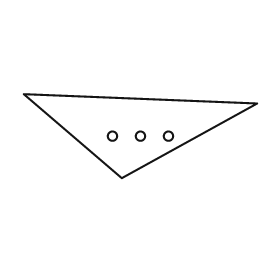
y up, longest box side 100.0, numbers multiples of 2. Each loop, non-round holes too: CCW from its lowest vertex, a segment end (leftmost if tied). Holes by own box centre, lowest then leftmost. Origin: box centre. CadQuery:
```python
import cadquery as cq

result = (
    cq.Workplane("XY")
    .moveTo(-8.0, -18.0)
    .lineTo(50.0, 14.0)
    .lineTo(-50.0, 18.0)
    .close()
    .moveTo(-12.0, 0.0)
    .circle(2.0)
    .moveTo(0.0, 0.0)
    .circle(2.0)
    .moveTo(12.0, 0.0)
    .circle(2.0)
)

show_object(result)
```